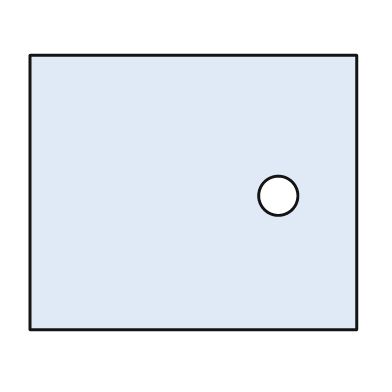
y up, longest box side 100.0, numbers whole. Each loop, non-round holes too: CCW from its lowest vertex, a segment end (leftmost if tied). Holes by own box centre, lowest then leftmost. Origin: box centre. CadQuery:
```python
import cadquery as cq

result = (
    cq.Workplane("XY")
    .moveTo(-50.0, -42.0)
    .lineTo(50.0, -42.0)
    .lineTo(50.0, 42.0)
    .lineTo(-50.0, 42.0)
    .close()
    .moveTo(26.0, -1.0)
    .circle(6.0)
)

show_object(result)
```